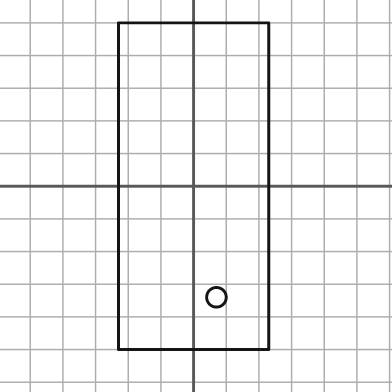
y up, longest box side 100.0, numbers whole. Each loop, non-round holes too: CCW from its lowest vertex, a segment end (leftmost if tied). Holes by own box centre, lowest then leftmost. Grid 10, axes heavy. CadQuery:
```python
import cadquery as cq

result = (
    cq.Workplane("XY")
    .moveTo(-23.0, -50.0)
    .lineTo(23.0, -50.0)
    .lineTo(23.0, 50.0)
    .lineTo(-23.0, 50.0)
    .close()
    .moveTo(7.0, -34.0)
    .circle(3.0)
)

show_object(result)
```